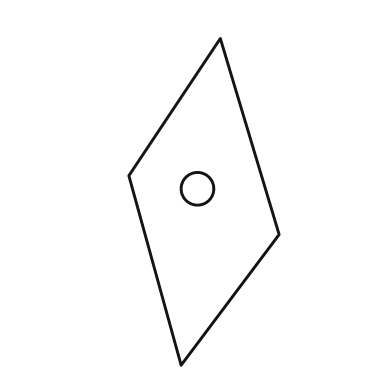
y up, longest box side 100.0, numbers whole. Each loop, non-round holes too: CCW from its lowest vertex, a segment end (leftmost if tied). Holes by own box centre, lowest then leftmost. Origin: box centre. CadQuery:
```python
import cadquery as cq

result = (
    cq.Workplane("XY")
    .moveTo(-7.0, -50.0)
    .lineTo(23.0, -10.0)
    .lineTo(5.0, 50.0)
    .lineTo(-23.0, 8.0)
    .close()
    .moveTo(-2.0, 4.0)
    .circle(5.0)
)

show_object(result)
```